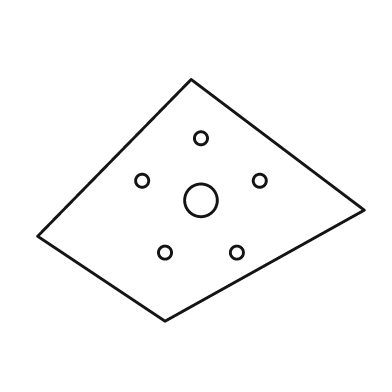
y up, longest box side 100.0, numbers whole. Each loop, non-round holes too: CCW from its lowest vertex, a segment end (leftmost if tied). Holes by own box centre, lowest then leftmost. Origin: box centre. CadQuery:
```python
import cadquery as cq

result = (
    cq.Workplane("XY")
    .moveTo(-11.0, -37.0)
    .lineTo(50.0, -3.0)
    .lineTo(-3.0, 37.0)
    .lineTo(-50.0, -11.0)
    .close()
    .moveTo(-11.0, -16.0)
    .circle(2.0)
    .moveTo(11.0, -16.0)
    .circle(2.0)
    .moveTo(0.0, 0.0)
    .circle(5.0)
    .moveTo(-18.0, 6.0)
    .circle(2.0)
    .moveTo(18.0, 6.0)
    .circle(2.0)
    .moveTo(0.0, 19.0)
    .circle(2.0)
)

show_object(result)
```